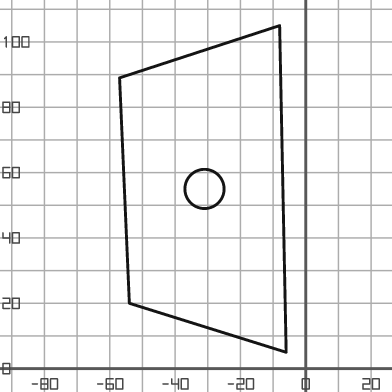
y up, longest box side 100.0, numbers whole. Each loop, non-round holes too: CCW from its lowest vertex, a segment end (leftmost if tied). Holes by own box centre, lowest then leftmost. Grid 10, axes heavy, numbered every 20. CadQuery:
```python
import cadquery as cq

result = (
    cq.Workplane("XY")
    .moveTo(-6.0, 5.0)
    .lineTo(-8.0, 105.0)
    .lineTo(-57.0, 89.0)
    .lineTo(-54.0, 20.0)
    .close()
    .moveTo(-31.0, 55.0)
    .circle(6.0)
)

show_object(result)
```